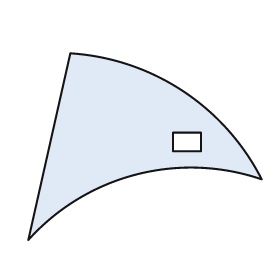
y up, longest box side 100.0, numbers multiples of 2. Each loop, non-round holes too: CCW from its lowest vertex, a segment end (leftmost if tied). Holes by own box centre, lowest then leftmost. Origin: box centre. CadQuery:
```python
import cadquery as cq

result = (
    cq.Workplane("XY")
    .moveTo(-50.0, -40.0)
    .threePointArc((-4.0, -12.0), (50.0, -14.0))
    .threePointArc((16.0, 24.0), (-32.0, 40.0))
    .close()
    .moveTo(12.0, -2.0)
    .lineTo(24.0, -2.0)
    .lineTo(24.0, 6.0)
    .lineTo(12.0, 6.0)
    .close()
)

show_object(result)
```